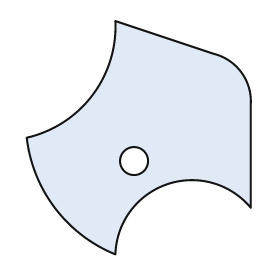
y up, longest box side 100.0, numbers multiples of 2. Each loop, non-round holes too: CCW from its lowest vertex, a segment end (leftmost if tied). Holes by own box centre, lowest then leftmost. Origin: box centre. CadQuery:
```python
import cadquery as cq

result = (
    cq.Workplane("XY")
    .moveTo(-10.0, -50.0)
    .threePointArc((12.0, -20.0), (48.0, -30.0))
    .lineTo(48.0, 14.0)
    .threePointArc((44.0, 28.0), (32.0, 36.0))
    .lineTo(-10.0, 50.0)
    .threePointArc((-20.0, 18.0), (-48.0, 0.0))
    .threePointArc((-36.0, -30.0), (-10.0, -50.0))
    .close()
    .moveTo(-2.0, -10.0)
    .circle(6.0)
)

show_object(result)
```